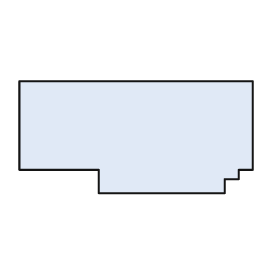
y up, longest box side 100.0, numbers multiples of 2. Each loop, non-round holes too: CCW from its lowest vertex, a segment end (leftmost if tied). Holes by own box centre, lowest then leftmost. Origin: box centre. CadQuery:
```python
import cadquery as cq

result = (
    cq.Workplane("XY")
    .moveTo(-16.0, -24.0)
    .lineTo(38.0, -24.0)
    .lineTo(38.0, -18.0)
    .lineTo(44.0, -18.0)
    .lineTo(44.0, -14.0)
    .lineTo(50.0, -14.0)
    .lineTo(50.0, 24.0)
    .lineTo(-50.0, 24.0)
    .lineTo(-50.0, -14.0)
    .lineTo(-16.0, -14.0)
    .close()
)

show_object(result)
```